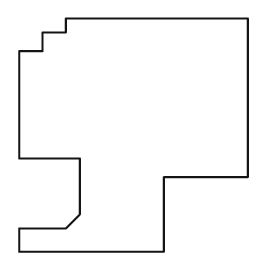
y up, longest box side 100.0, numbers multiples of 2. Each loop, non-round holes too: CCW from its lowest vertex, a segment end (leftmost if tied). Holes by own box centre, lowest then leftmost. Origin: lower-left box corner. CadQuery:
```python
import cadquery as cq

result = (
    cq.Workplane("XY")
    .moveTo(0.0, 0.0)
    .lineTo(62.0, 0.0)
    .lineTo(62.0, 32.0)
    .lineTo(98.0, 32.0)
    .lineTo(98.0, 100.0)
    .lineTo(20.0, 100.0)
    .lineTo(20.0, 94.0)
    .lineTo(10.0, 94.0)
    .lineTo(10.0, 86.0)
    .lineTo(0.0, 86.0)
    .lineTo(0.0, 40.0)
    .lineTo(26.0, 40.0)
    .lineTo(26.0, 16.0)
    .lineTo(20.0, 10.0)
    .lineTo(0.0, 10.0)
    .close()
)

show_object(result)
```